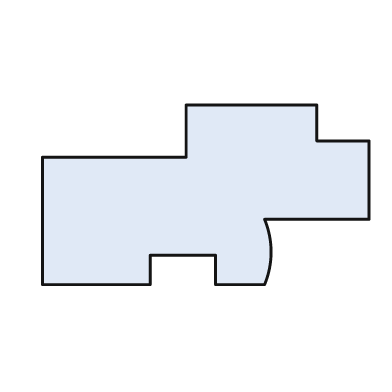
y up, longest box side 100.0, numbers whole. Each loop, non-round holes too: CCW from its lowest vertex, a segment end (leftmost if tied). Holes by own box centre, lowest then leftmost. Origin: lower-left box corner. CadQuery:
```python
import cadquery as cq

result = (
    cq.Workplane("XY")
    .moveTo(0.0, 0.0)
    .lineTo(33.0, 0.0)
    .lineTo(33.0, 9.0)
    .lineTo(53.0, 9.0)
    .lineTo(53.0, 0.0)
    .lineTo(68.0, 0.0)
    .threePointArc((70.0, 10.0), (68.0, 20.0))
    .lineTo(100.0, 20.0)
    .lineTo(100.0, 44.0)
    .lineTo(84.0, 44.0)
    .lineTo(84.0, 55.0)
    .lineTo(44.0, 55.0)
    .lineTo(44.0, 39.0)
    .lineTo(0.0, 39.0)
    .close()
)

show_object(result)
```